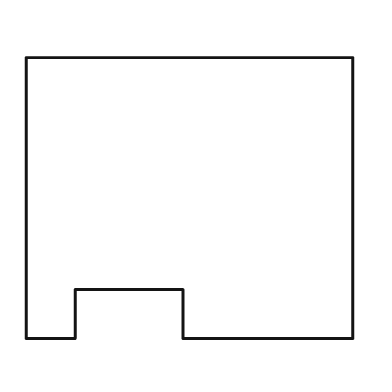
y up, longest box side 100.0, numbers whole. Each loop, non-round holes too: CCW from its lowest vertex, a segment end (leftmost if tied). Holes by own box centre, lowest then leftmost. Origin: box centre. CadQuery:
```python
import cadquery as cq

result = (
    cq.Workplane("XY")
    .moveTo(-50.0, -43.0)
    .lineTo(-35.0, -43.0)
    .lineTo(-35.0, -28.0)
    .lineTo(-2.0, -28.0)
    .lineTo(-2.0, -43.0)
    .lineTo(50.0, -43.0)
    .lineTo(50.0, 43.0)
    .lineTo(-50.0, 43.0)
    .close()
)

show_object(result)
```